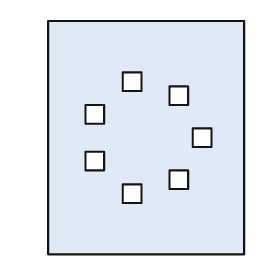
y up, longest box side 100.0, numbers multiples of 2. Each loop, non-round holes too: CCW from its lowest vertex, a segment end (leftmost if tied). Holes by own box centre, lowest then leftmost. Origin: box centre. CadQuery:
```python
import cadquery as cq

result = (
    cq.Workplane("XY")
    .moveTo(-42.0, -50.0)
    .lineTo(42.0, -50.0)
    .lineTo(42.0, 50.0)
    .lineTo(-42.0, 50.0)
    .close()
    .moveTo(-10.0, -28.0)
    .lineTo(-2.0, -28.0)
    .lineTo(-2.0, -20.0)
    .lineTo(-10.0, -20.0)
    .close()
    .moveTo(10.0, -22.0)
    .lineTo(18.0, -22.0)
    .lineTo(18.0, -14.0)
    .lineTo(10.0, -14.0)
    .close()
    .moveTo(-26.0, -14.0)
    .lineTo(-18.0, -14.0)
    .lineTo(-18.0, -6.0)
    .lineTo(-26.0, -6.0)
    .close()
    .moveTo(20.0, -4.0)
    .lineTo(28.0, -4.0)
    .lineTo(28.0, 4.0)
    .lineTo(20.0, 4.0)
    .close()
    .moveTo(-26.0, 6.0)
    .lineTo(-18.0, 6.0)
    .lineTo(-18.0, 14.0)
    .lineTo(-26.0, 14.0)
    .close()
    .moveTo(10.0, 14.0)
    .lineTo(18.0, 14.0)
    .lineTo(18.0, 22.0)
    .lineTo(10.0, 22.0)
    .close()
    .moveTo(-10.0, 20.0)
    .lineTo(-2.0, 20.0)
    .lineTo(-2.0, 28.0)
    .lineTo(-10.0, 28.0)
    .close()
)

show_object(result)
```